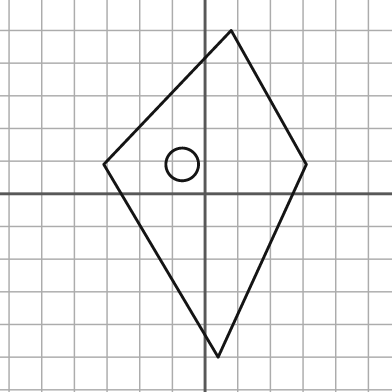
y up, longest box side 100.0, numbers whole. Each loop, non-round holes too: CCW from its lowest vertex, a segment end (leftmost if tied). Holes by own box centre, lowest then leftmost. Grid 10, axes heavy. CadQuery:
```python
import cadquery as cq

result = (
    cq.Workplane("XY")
    .moveTo(4.0, -50.0)
    .lineTo(31.0, 9.0)
    .lineTo(8.0, 50.0)
    .lineTo(-31.0, 9.0)
    .close()
    .moveTo(-7.0, 9.0)
    .circle(5.0)
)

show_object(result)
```